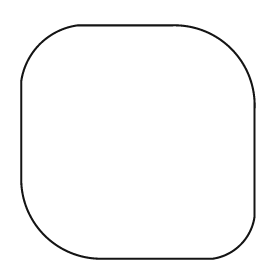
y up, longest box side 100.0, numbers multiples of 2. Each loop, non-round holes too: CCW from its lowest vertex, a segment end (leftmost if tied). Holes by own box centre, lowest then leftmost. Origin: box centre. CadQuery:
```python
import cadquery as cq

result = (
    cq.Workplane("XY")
    .moveTo(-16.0, -50.0)
    .lineTo(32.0, -50.0)
    .threePointArc((44.0, -44.0), (50.0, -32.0))
    .lineTo(50.0, 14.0)
    .threePointArc((40.0, 40.0), (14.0, 50.0))
    .lineTo(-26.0, 50.0)
    .threePointArc((-42.0, 42.0), (-50.0, 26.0))
    .lineTo(-50.0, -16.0)
    .threePointArc((-40.0, -40.0), (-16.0, -50.0))
    .close()
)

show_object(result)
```